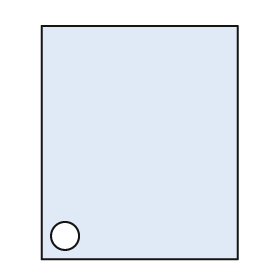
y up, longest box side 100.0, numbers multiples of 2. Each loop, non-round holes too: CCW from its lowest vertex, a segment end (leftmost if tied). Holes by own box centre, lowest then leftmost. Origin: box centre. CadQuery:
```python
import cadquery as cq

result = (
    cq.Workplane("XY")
    .moveTo(-42.0, -50.0)
    .lineTo(42.0, -50.0)
    .lineTo(42.0, 50.0)
    .lineTo(-42.0, 50.0)
    .close()
    .moveTo(-32.0, -40.0)
    .circle(6.0)
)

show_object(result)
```